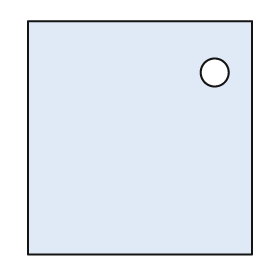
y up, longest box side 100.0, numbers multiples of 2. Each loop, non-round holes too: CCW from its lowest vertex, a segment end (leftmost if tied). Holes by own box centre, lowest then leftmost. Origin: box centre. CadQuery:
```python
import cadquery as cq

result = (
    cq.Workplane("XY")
    .moveTo(-48.0, -50.0)
    .lineTo(48.0, -50.0)
    .lineTo(48.0, 50.0)
    .lineTo(-48.0, 50.0)
    .close()
    .moveTo(32.0, 28.0)
    .circle(6.0)
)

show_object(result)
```